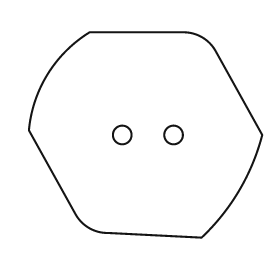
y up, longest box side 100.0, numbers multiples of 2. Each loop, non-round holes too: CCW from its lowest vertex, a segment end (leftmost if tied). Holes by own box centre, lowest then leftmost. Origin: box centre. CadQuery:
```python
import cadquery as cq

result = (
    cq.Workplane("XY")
    .moveTo(24.0, -44.0)
    .threePointArc((40.0, -24.0), (50.0, 0.0))
    .lineTo(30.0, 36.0)
    .threePointArc((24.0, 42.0), (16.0, 44.0))
    .lineTo(-24.0, 44.0)
    .threePointArc((-42.0, 26.0), (-50.0, 2.0))
    .lineTo(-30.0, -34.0)
    .threePointArc((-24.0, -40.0), (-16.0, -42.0))
    .close()
    .moveTo(-10.0, 0.0)
    .circle(4.0)
    .moveTo(12.0, 0.0)
    .circle(4.0)
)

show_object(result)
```